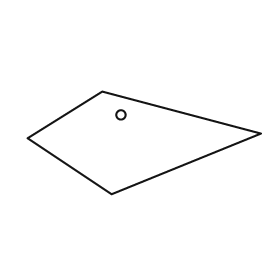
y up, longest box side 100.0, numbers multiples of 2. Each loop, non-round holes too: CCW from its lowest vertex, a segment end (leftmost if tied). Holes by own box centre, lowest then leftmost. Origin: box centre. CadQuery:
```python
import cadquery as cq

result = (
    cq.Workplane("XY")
    .moveTo(-14.0, -22.0)
    .lineTo(50.0, 4.0)
    .lineTo(-18.0, 22.0)
    .lineTo(-50.0, 2.0)
    .close()
    .moveTo(-10.0, 12.0)
    .circle(2.0)
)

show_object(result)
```